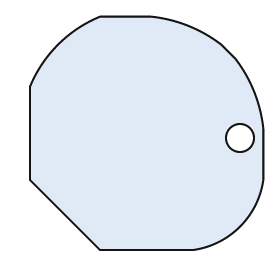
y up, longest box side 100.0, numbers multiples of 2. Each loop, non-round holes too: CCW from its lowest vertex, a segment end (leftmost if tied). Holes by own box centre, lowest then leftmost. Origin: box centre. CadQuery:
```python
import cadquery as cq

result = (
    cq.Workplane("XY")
    .moveTo(-20.0, -50.0)
    .lineTo(20.0, -50.0)
    .threePointArc((40.0, -40.0), (50.0, -20.0))
    .lineTo(50.0, 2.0)
    .threePointArc((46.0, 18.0), (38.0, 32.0))
    .lineTo(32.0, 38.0)
    .threePointArc((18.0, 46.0), (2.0, 50.0))
    .lineTo(-20.0, 50.0)
    .threePointArc((-38.0, 38.0), (-50.0, 20.0))
    .lineTo(-50.0, -20.0)
    .close()
    .moveTo(40.0, -2.0)
    .circle(6.0)
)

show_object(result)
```